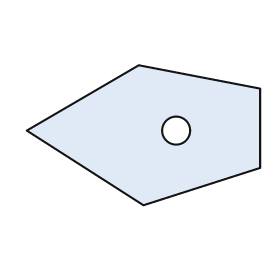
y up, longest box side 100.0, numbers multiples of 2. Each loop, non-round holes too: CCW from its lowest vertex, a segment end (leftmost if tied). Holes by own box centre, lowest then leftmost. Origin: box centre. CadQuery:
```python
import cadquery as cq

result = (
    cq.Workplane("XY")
    .moveTo(0.0, -30.0)
    .lineTo(50.0, -14.0)
    .lineTo(50.0, 20.0)
    .lineTo(-2.0, 30.0)
    .lineTo(-50.0, 2.0)
    .close()
    .moveTo(14.0, 2.0)
    .circle(6.0)
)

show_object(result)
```